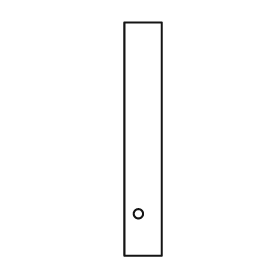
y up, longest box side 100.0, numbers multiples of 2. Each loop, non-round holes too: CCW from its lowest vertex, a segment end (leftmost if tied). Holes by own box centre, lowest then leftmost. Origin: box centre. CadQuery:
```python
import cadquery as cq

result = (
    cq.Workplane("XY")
    .moveTo(-8.0, -50.0)
    .lineTo(8.0, -50.0)
    .lineTo(8.0, 50.0)
    .lineTo(-8.0, 50.0)
    .close()
    .moveTo(-2.0, -32.0)
    .circle(2.0)
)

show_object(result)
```